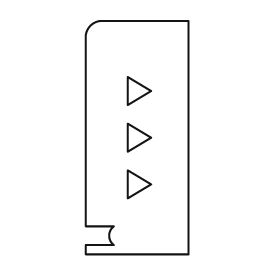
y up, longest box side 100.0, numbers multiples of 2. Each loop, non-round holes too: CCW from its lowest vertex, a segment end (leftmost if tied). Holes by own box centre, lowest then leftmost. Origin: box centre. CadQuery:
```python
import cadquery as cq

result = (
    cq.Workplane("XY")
    .moveTo(-22.0, -50.0)
    .lineTo(22.0, -50.0)
    .lineTo(22.0, 50.0)
    .lineTo(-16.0, 50.0)
    .threePointArc((-20.0, 48.0), (-22.0, 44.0))
    .lineTo(-22.0, -38.0)
    .lineTo(-10.0, -38.0)
    .threePointArc((-12.0, -42.0), (-10.0, -46.0))
    .lineTo(-22.0, -46.0)
    .close()
    .moveTo(-4.0, -26.0)
    .lineTo(6.0, -20.0)
    .lineTo(-4.0, -14.0)
    .close()
    .moveTo(-4.0, -6.0)
    .lineTo(6.0, 0.0)
    .lineTo(-4.0, 6.0)
    .close()
    .moveTo(-4.0, 14.0)
    .lineTo(6.0, 20.0)
    .lineTo(-4.0, 26.0)
    .close()
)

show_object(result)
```